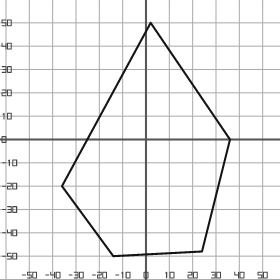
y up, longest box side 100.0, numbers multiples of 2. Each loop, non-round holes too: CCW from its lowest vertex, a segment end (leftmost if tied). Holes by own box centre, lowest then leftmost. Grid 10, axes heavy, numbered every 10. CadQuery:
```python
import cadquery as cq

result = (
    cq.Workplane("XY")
    .moveTo(-14.0, -50.0)
    .lineTo(24.0, -48.0)
    .lineTo(36.0, 0.0)
    .lineTo(2.0, 50.0)
    .lineTo(-36.0, -20.0)
    .close()
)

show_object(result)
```